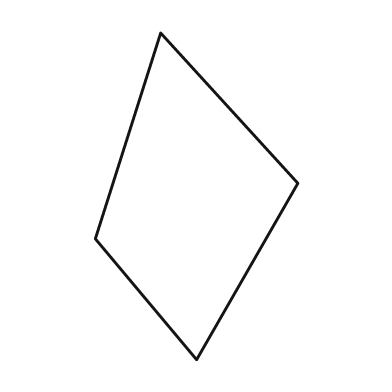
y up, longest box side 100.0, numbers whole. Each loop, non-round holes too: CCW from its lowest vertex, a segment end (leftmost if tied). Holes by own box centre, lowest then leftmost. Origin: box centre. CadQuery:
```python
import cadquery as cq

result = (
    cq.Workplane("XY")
    .moveTo(0.0, -50.0)
    .lineTo(31.0, 4.0)
    .lineTo(-11.0, 50.0)
    .lineTo(-31.0, -13.0)
    .close()
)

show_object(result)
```